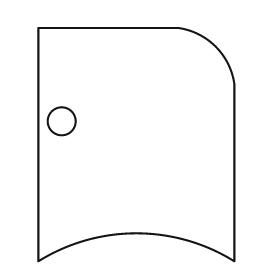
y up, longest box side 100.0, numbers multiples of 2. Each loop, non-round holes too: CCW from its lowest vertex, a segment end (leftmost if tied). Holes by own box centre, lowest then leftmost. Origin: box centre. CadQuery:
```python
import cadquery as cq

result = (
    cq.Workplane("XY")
    .moveTo(-42.0, -50.0)
    .threePointArc((0.0, -38.0), (42.0, -50.0))
    .lineTo(42.0, 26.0)
    .threePointArc((34.0, 42.0), (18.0, 50.0))
    .lineTo(-42.0, 50.0)
    .close()
    .moveTo(-32.0, 10.0)
    .circle(6.0)
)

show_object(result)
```